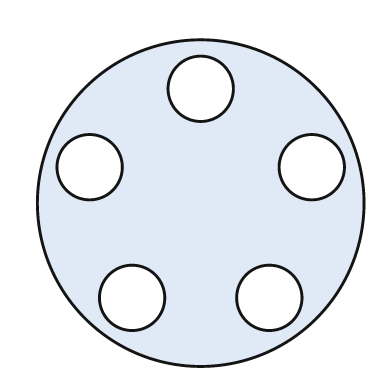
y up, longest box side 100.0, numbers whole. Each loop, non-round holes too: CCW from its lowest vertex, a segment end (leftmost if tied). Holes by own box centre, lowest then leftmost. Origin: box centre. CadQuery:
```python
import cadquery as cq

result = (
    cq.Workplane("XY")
    .moveTo(0.0, 0.0)
    .circle(50.0)
    .moveTo(-21.0, -29.0)
    .circle(10.0)
    .moveTo(21.0, -29.0)
    .circle(10.0)
    .moveTo(-34.0, 11.0)
    .circle(10.0)
    .moveTo(34.0, 11.0)
    .circle(10.0)
    .moveTo(0.0, 35.0)
    .circle(10.0)
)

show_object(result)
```